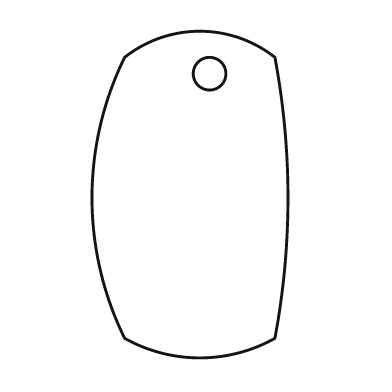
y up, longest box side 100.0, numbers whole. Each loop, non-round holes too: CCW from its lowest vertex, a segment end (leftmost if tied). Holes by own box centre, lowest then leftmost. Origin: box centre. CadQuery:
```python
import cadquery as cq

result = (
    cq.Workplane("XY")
    .moveTo(-20.0, -44.0)
    .threePointArc((3.0, -50.0), (26.0, -44.0))
    .threePointArc((30.0, -1.0), (26.0, 42.0))
    .threePointArc((3.0, 50.0), (-20.0, 42.0))
    .threePointArc((-30.0, -1.0), (-20.0, -44.0))
    .close()
    .moveTo(6.0, 37.0)
    .circle(5.0)
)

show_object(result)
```